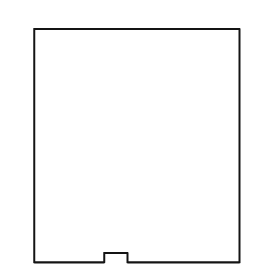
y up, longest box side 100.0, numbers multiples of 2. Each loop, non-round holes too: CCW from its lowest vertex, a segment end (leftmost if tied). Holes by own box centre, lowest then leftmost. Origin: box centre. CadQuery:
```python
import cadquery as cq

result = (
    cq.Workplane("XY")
    .moveTo(-44.0, -50.0)
    .lineTo(-14.0, -50.0)
    .lineTo(-14.0, -46.0)
    .lineTo(-4.0, -46.0)
    .lineTo(-4.0, -50.0)
    .lineTo(44.0, -50.0)
    .lineTo(44.0, 50.0)
    .lineTo(-44.0, 50.0)
    .close()
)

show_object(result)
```